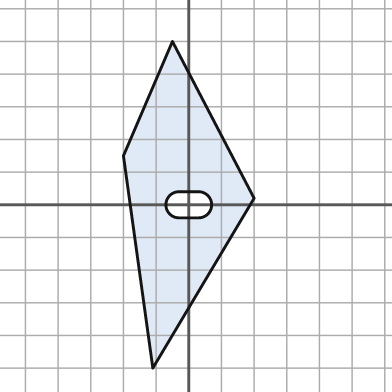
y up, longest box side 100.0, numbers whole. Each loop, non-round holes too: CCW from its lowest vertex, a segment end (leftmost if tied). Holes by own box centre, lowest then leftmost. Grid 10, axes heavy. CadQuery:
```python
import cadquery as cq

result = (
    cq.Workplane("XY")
    .moveTo(-11.0, -50.0)
    .lineTo(20.0, 2.0)
    .lineTo(-5.0, 50.0)
    .lineTo(-20.0, 15.0)
    .close()
    .moveTo(-3.0, -4.0)
    .lineTo(3.0, -4.0)
    .threePointArc((7.0, 0.0), (3.0, 4.0))
    .lineTo(-3.0, 4.0)
    .threePointArc((-7.0, 0.0), (-3.0, -4.0))
    .close()
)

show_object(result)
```